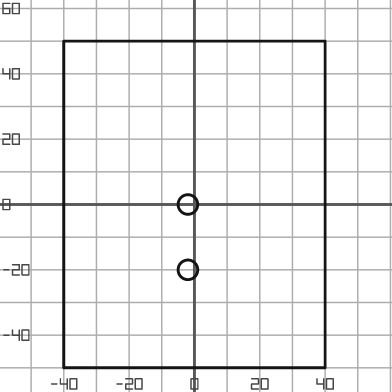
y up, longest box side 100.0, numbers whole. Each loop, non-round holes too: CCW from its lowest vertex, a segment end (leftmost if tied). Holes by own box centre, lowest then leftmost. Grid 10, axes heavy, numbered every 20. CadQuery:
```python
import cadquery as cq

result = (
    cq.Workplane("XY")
    .moveTo(-40.0, -50.0)
    .lineTo(40.0, -50.0)
    .lineTo(40.0, 50.0)
    .lineTo(-40.0, 50.0)
    .close()
    .moveTo(-2.0, -20.0)
    .circle(3.0)
    .moveTo(-2.0, 0.0)
    .circle(3.0)
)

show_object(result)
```